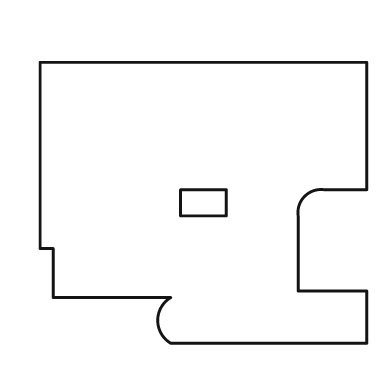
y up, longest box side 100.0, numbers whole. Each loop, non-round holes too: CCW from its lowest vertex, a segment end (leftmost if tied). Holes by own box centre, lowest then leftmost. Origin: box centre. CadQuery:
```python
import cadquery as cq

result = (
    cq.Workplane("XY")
    .moveTo(-10.0, -43.0)
    .lineTo(50.0, -43.0)
    .lineTo(50.0, -27.0)
    .lineTo(29.0, -27.0)
    .lineTo(29.0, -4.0)
    .threePointArc((31.0, 2.0), (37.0, 4.0))
    .lineTo(50.0, 4.0)
    .lineTo(50.0, 43.0)
    .lineTo(-50.0, 43.0)
    .lineTo(-50.0, -14.0)
    .lineTo(-46.0, -14.0)
    .lineTo(-46.0, -29.0)
    .lineTo(-10.0, -29.0)
    .threePointArc((-14.0, -36.0), (-10.0, -43.0))
    .close()
    .moveTo(-7.0, -4.0)
    .lineTo(7.0, -4.0)
    .lineTo(7.0, 4.0)
    .lineTo(-7.0, 4.0)
    .close()
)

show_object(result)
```